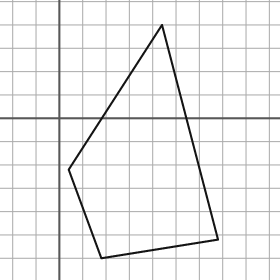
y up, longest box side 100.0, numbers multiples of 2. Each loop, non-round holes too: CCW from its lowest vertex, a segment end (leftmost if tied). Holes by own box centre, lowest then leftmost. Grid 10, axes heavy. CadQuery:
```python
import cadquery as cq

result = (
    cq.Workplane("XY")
    .moveTo(18.0, -60.0)
    .lineTo(68.0, -52.0)
    .lineTo(44.0, 40.0)
    .lineTo(4.0, -22.0)
    .close()
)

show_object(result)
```